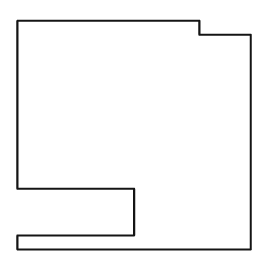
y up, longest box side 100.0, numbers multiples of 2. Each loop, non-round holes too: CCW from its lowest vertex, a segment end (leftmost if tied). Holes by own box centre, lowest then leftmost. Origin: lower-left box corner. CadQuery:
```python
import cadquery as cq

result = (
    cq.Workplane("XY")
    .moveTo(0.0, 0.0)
    .lineTo(100.0, 0.0)
    .lineTo(100.0, 92.0)
    .lineTo(78.0, 92.0)
    .lineTo(78.0, 98.0)
    .lineTo(0.0, 98.0)
    .lineTo(0.0, 26.0)
    .lineTo(50.0, 26.0)
    .lineTo(50.0, 6.0)
    .lineTo(0.0, 6.0)
    .close()
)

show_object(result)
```